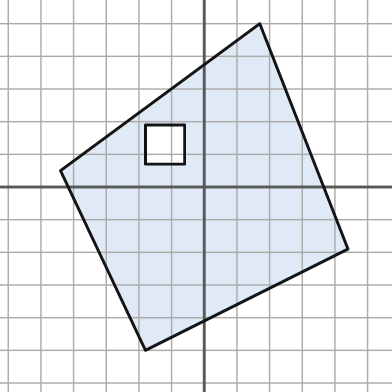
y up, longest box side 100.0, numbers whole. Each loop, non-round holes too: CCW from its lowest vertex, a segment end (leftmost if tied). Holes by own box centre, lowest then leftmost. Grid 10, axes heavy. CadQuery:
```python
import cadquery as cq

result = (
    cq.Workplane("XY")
    .moveTo(-18.0, -50.0)
    .lineTo(44.0, -19.0)
    .lineTo(17.0, 50.0)
    .lineTo(-44.0, 5.0)
    .close()
    .moveTo(-18.0, 7.0)
    .lineTo(-6.0, 7.0)
    .lineTo(-6.0, 19.0)
    .lineTo(-18.0, 19.0)
    .close()
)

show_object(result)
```